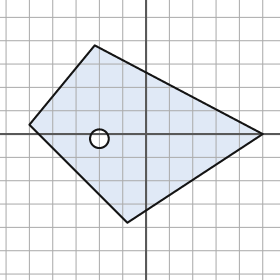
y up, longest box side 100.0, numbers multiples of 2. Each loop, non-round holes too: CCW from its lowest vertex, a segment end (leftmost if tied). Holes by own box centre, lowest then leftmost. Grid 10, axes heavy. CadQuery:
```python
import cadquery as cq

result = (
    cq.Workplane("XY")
    .moveTo(-8.0, -38.0)
    .lineTo(50.0, 0.0)
    .lineTo(-22.0, 38.0)
    .lineTo(-50.0, 4.0)
    .close()
    .moveTo(-20.0, -2.0)
    .circle(4.0)
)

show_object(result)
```